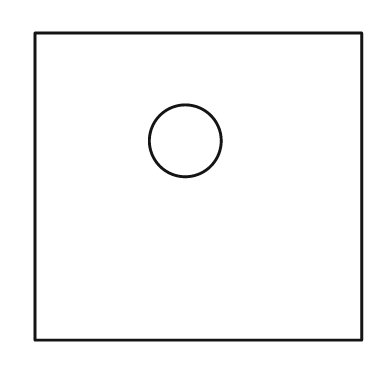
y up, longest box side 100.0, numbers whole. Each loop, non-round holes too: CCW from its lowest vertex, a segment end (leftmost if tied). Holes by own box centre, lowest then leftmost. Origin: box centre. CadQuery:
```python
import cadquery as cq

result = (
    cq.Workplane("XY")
    .moveTo(-50.0, -47.0)
    .lineTo(50.0, -47.0)
    .lineTo(50.0, 47.0)
    .lineTo(-50.0, 47.0)
    .close()
    .moveTo(-4.0, 14.0)
    .circle(11.0)
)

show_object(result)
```